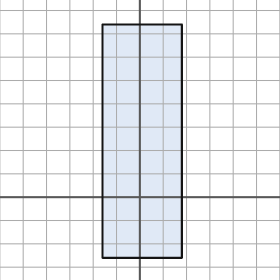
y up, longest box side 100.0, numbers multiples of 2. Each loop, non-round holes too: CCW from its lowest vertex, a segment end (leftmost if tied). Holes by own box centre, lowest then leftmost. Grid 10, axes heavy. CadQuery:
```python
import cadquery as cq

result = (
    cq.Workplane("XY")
    .moveTo(-16.0, -26.0)
    .lineTo(18.0, -26.0)
    .lineTo(18.0, 74.0)
    .lineTo(-16.0, 74.0)
    .close()
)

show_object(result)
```